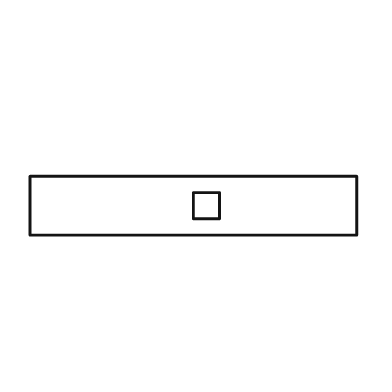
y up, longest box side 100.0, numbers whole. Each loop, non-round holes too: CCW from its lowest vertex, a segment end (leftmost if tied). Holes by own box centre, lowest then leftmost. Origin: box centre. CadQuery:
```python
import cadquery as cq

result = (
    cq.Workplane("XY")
    .moveTo(-50.0, -9.0)
    .lineTo(50.0, -9.0)
    .lineTo(50.0, 9.0)
    .lineTo(-50.0, 9.0)
    .close()
    .moveTo(0.0, -4.0)
    .lineTo(8.0, -4.0)
    .lineTo(8.0, 4.0)
    .lineTo(0.0, 4.0)
    .close()
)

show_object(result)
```